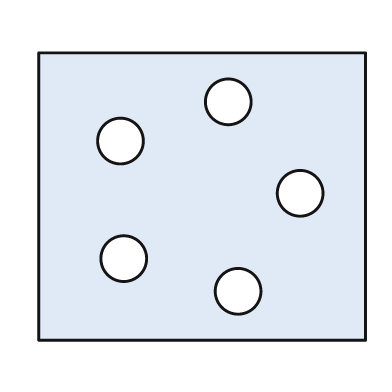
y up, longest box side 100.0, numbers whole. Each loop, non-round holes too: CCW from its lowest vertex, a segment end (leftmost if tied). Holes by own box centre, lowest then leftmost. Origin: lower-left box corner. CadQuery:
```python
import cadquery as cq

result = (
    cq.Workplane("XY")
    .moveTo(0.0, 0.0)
    .lineTo(100.0, 0.0)
    .lineTo(100.0, 88.0)
    .lineTo(0.0, 88.0)
    .close()
    .moveTo(61.0, 15.0)
    .circle(7.0)
    .moveTo(26.0, 25.0)
    .circle(7.0)
    .moveTo(80.0, 45.0)
    .circle(7.0)
    .moveTo(25.0, 61.0)
    .circle(7.0)
    .moveTo(58.0, 73.0)
    .circle(7.0)
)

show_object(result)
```